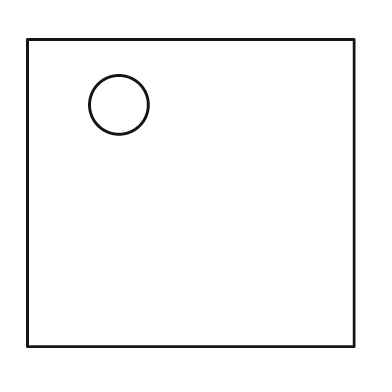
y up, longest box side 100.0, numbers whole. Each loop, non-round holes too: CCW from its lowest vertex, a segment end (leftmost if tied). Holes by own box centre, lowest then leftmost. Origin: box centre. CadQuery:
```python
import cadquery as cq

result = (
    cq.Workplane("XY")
    .moveTo(-50.0, -47.0)
    .lineTo(50.0, -47.0)
    .lineTo(50.0, 47.0)
    .lineTo(-50.0, 47.0)
    .close()
    .moveTo(-22.0, 27.0)
    .circle(9.0)
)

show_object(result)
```